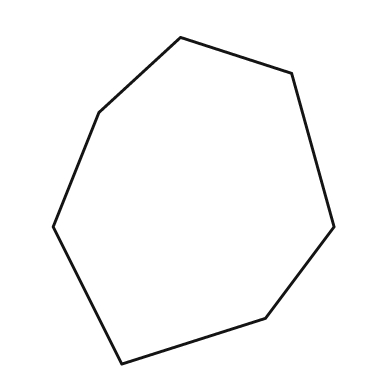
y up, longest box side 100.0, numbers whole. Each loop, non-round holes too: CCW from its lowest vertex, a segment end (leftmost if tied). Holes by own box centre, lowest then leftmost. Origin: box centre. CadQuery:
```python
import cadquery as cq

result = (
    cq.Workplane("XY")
    .moveTo(-22.0, -50.0)
    .lineTo(22.0, -36.0)
    .lineTo(43.0, -8.0)
    .lineTo(30.0, 39.0)
    .lineTo(-4.0, 50.0)
    .lineTo(-29.0, 27.0)
    .lineTo(-43.0, -8.0)
    .close()
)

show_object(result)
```